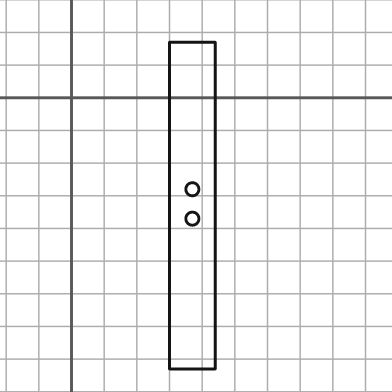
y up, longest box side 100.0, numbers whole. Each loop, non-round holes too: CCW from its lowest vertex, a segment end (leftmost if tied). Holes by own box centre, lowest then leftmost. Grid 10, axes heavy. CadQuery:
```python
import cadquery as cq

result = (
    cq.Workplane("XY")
    .moveTo(30.0, -83.0)
    .lineTo(44.0, -83.0)
    .lineTo(44.0, 17.0)
    .lineTo(30.0, 17.0)
    .close()
    .moveTo(37.0, -37.0)
    .circle(2.0)
    .moveTo(37.0, -28.0)
    .circle(2.0)
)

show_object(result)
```